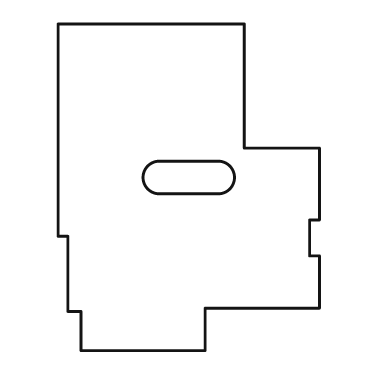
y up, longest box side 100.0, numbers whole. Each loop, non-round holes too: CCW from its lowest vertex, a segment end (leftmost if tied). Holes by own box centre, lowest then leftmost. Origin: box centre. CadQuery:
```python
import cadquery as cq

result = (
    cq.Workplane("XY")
    .moveTo(-33.0, -50.0)
    .lineTo(5.0, -50.0)
    .lineTo(5.0, -37.0)
    .lineTo(40.0, -37.0)
    .lineTo(40.0, -21.0)
    .lineTo(37.0, -21.0)
    .lineTo(37.0, -10.0)
    .lineTo(40.0, -10.0)
    .lineTo(40.0, 12.0)
    .lineTo(17.0, 12.0)
    .lineTo(17.0, 50.0)
    .lineTo(-40.0, 50.0)
    .lineTo(-40.0, -15.0)
    .lineTo(-37.0, -15.0)
    .lineTo(-37.0, -38.0)
    .lineTo(-33.0, -38.0)
    .close()
    .moveTo(-9.0, -2.0)
    .lineTo(9.0, -2.0)
    .threePointArc((14.0, 3.0), (9.0, 8.0))
    .lineTo(-9.0, 8.0)
    .threePointArc((-14.0, 3.0), (-9.0, -2.0))
    .close()
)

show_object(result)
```